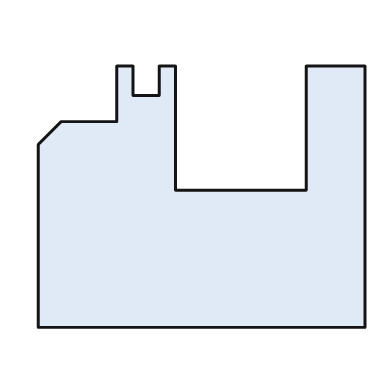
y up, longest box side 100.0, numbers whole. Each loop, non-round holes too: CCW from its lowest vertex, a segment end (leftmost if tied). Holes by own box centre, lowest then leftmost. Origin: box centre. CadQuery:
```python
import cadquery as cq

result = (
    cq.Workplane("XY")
    .moveTo(-50.0, -40.0)
    .lineTo(50.0, -40.0)
    .lineTo(50.0, 40.0)
    .lineTo(32.0, 40.0)
    .lineTo(32.0, 2.0)
    .lineTo(-8.0, 2.0)
    .lineTo(-8.0, 40.0)
    .lineTo(-13.0, 40.0)
    .lineTo(-13.0, 31.0)
    .lineTo(-21.0, 31.0)
    .lineTo(-21.0, 40.0)
    .lineTo(-26.0, 40.0)
    .lineTo(-26.0, 23.0)
    .lineTo(-43.0, 23.0)
    .lineTo(-50.0, 16.0)
    .close()
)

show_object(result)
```